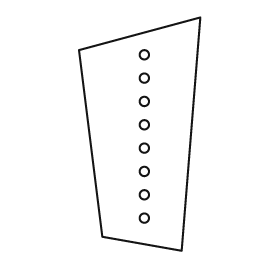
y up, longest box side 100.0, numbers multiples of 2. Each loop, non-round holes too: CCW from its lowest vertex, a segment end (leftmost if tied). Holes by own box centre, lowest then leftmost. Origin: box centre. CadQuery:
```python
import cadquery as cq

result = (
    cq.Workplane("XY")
    .moveTo(18.0, -50.0)
    .lineTo(26.0, 50.0)
    .lineTo(-26.0, 36.0)
    .lineTo(-16.0, -44.0)
    .close()
    .moveTo(2.0, -36.0)
    .circle(2.0)
    .moveTo(2.0, -26.0)
    .circle(2.0)
    .moveTo(2.0, -16.0)
    .circle(2.0)
    .moveTo(2.0, -6.0)
    .circle(2.0)
    .moveTo(2.0, 4.0)
    .circle(2.0)
    .moveTo(2.0, 14.0)
    .circle(2.0)
    .moveTo(2.0, 24.0)
    .circle(2.0)
    .moveTo(2.0, 34.0)
    .circle(2.0)
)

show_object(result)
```